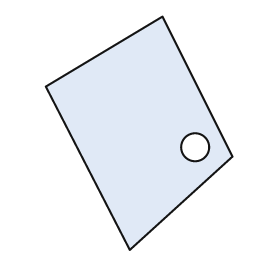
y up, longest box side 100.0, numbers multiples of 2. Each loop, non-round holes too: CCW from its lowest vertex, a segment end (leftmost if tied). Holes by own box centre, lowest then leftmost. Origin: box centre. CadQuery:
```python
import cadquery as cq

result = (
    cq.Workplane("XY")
    .moveTo(-4.0, -50.0)
    .lineTo(40.0, -10.0)
    .lineTo(10.0, 50.0)
    .lineTo(-40.0, 20.0)
    .close()
    .moveTo(24.0, -6.0)
    .circle(6.0)
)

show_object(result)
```